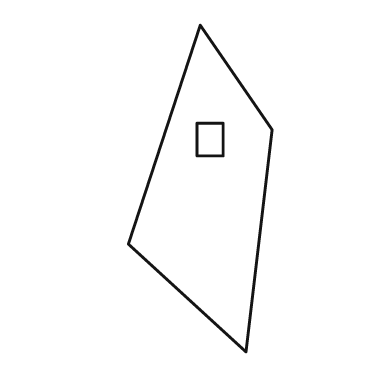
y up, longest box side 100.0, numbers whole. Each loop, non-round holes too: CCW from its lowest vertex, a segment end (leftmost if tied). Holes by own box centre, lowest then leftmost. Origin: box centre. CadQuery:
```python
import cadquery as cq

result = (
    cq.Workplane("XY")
    .moveTo(14.0, -50.0)
    .lineTo(22.0, 18.0)
    .lineTo(0.0, 50.0)
    .lineTo(-22.0, -17.0)
    .close()
    .moveTo(-1.0, 10.0)
    .lineTo(7.0, 10.0)
    .lineTo(7.0, 20.0)
    .lineTo(-1.0, 20.0)
    .close()
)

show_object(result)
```